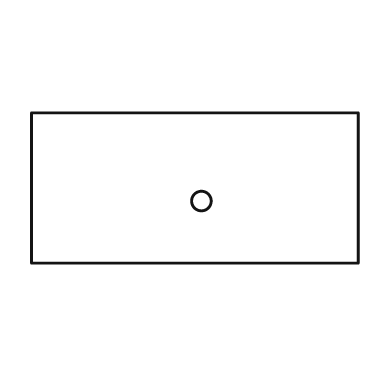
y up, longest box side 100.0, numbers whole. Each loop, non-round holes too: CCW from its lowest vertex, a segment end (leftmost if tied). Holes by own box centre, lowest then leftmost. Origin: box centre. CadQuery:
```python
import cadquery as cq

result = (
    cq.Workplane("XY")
    .moveTo(-50.0, -23.0)
    .lineTo(50.0, -23.0)
    .lineTo(50.0, 23.0)
    .lineTo(-50.0, 23.0)
    .close()
    .moveTo(2.0, -4.0)
    .circle(3.0)
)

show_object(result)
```